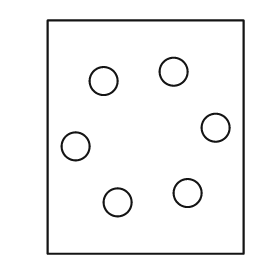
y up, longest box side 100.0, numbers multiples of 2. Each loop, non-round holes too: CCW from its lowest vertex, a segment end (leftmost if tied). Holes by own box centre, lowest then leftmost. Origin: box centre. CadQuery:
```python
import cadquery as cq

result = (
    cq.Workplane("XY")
    .moveTo(-42.0, -50.0)
    .lineTo(42.0, -50.0)
    .lineTo(42.0, 50.0)
    .lineTo(-42.0, 50.0)
    .close()
    .moveTo(-12.0, -28.0)
    .circle(6.0)
    .moveTo(18.0, -24.0)
    .circle(6.0)
    .moveTo(-30.0, -4.0)
    .circle(6.0)
    .moveTo(30.0, 4.0)
    .circle(6.0)
    .moveTo(-18.0, 24.0)
    .circle(6.0)
    .moveTo(12.0, 28.0)
    .circle(6.0)
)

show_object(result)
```